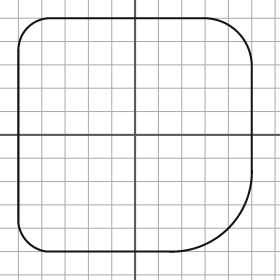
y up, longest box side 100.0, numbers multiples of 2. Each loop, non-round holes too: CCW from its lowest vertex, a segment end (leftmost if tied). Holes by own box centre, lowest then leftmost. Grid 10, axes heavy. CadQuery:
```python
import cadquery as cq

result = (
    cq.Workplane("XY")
    .moveTo(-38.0, -50.0)
    .lineTo(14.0, -50.0)
    .threePointArc((40.0, -40.0), (50.0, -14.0))
    .lineTo(50.0, 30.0)
    .threePointArc((44.0, 44.0), (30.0, 50.0))
    .lineTo(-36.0, 50.0)
    .threePointArc((-46.0, 46.0), (-50.0, 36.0))
    .lineTo(-50.0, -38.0)
    .threePointArc((-46.0, -46.0), (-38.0, -50.0))
    .close()
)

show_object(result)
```